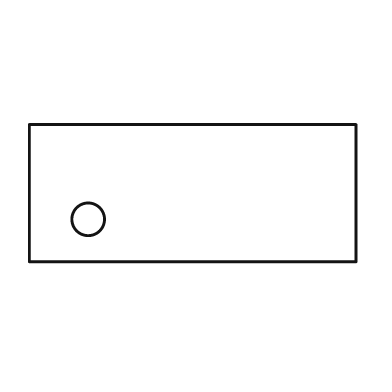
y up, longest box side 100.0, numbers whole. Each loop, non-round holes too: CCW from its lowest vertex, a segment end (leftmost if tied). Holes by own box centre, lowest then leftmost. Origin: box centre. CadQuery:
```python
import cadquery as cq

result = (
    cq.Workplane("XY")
    .moveTo(-50.0, -21.0)
    .lineTo(50.0, -21.0)
    .lineTo(50.0, 21.0)
    .lineTo(-50.0, 21.0)
    .close()
    .moveTo(-32.0, -8.0)
    .circle(5.0)
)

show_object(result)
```